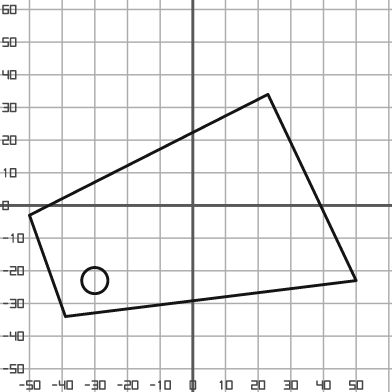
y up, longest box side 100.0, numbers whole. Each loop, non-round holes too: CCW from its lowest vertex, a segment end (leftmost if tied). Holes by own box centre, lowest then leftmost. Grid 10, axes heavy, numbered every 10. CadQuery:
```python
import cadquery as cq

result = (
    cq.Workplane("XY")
    .moveTo(-39.0, -34.0)
    .lineTo(50.0, -23.0)
    .lineTo(23.0, 34.0)
    .lineTo(-50.0, -3.0)
    .close()
    .moveTo(-30.0, -23.0)
    .circle(4.0)
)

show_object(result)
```